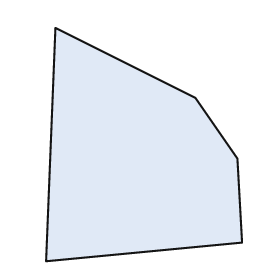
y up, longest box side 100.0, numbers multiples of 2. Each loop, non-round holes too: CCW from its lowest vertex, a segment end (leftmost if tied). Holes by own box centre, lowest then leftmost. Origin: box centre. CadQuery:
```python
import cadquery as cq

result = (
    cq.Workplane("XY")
    .moveTo(-42.0, -50.0)
    .lineTo(42.0, -42.0)
    .lineTo(40.0, -6.0)
    .lineTo(22.0, 20.0)
    .lineTo(-38.0, 50.0)
    .close()
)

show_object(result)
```